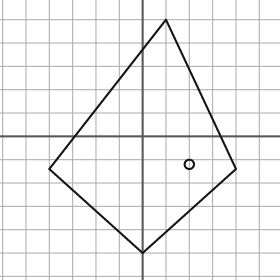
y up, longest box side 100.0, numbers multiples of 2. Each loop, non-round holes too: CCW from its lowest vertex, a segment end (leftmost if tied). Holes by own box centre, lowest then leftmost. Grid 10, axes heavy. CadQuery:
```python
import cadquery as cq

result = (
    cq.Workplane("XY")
    .moveTo(0.0, -50.0)
    .lineTo(40.0, -14.0)
    .lineTo(10.0, 50.0)
    .lineTo(-40.0, -14.0)
    .close()
    .moveTo(20.0, -12.0)
    .circle(2.0)
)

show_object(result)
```